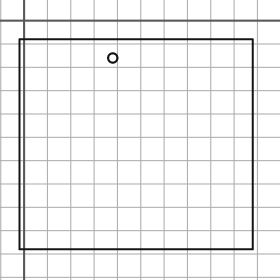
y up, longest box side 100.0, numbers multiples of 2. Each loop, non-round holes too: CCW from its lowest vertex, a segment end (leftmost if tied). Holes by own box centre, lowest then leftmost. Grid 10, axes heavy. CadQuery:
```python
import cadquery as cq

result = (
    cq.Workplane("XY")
    .moveTo(-2.0, -98.0)
    .lineTo(98.0, -98.0)
    .lineTo(98.0, -8.0)
    .lineTo(-2.0, -8.0)
    .close()
    .moveTo(38.0, -16.0)
    .circle(2.0)
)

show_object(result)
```